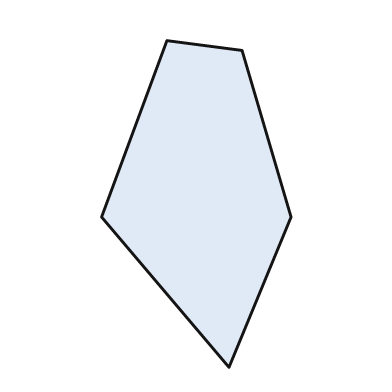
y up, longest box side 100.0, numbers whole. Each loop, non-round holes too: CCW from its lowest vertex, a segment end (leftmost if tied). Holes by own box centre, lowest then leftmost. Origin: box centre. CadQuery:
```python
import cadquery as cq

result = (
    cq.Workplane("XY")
    .moveTo(10.0, -50.0)
    .lineTo(29.0, -4.0)
    .lineTo(14.0, 47.0)
    .lineTo(-9.0, 50.0)
    .lineTo(-29.0, -4.0)
    .close()
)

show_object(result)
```